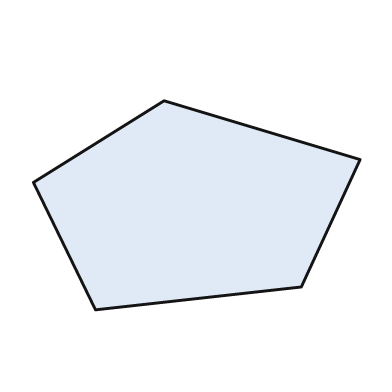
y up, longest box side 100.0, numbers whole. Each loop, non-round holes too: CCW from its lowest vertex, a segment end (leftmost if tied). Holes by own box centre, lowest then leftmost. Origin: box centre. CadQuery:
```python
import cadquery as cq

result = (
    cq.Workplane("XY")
    .moveTo(-31.0, -32.0)
    .lineTo(32.0, -25.0)
    .lineTo(50.0, 14.0)
    .lineTo(-10.0, 32.0)
    .lineTo(-50.0, 7.0)
    .close()
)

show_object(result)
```